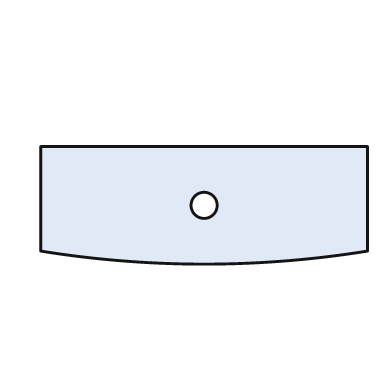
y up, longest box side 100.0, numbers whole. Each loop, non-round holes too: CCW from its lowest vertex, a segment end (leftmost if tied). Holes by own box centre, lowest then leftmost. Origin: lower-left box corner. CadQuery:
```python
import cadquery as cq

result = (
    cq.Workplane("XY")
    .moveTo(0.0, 4.0)
    .threePointArc((50.0, 0.0), (100.0, 4.0))
    .lineTo(100.0, 36.0)
    .lineTo(0.0, 36.0)
    .close()
    .moveTo(50.0, 18.0)
    .circle(4.0)
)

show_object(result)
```